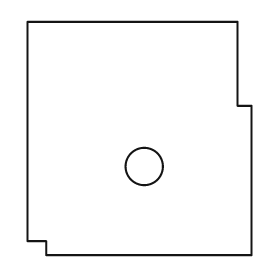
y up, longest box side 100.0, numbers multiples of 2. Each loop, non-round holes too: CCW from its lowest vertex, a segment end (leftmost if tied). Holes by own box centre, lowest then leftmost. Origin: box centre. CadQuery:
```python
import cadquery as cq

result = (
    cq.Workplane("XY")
    .moveTo(-40.0, -50.0)
    .lineTo(48.0, -50.0)
    .lineTo(48.0, 14.0)
    .lineTo(42.0, 14.0)
    .lineTo(42.0, 50.0)
    .lineTo(-48.0, 50.0)
    .lineTo(-48.0, -44.0)
    .lineTo(-40.0, -44.0)
    .close()
    .moveTo(2.0, -12.0)
    .circle(8.0)
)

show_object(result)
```